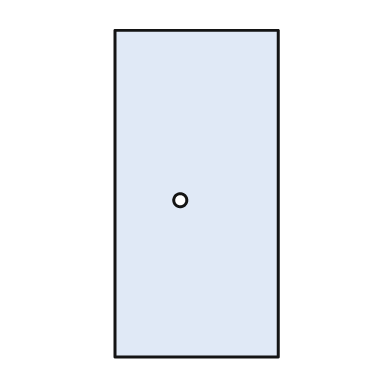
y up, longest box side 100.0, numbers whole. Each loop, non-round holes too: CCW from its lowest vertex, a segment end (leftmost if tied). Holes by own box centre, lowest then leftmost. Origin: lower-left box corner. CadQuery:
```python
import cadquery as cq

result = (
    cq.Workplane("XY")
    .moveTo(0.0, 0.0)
    .lineTo(50.0, 0.0)
    .lineTo(50.0, 100.0)
    .lineTo(0.0, 100.0)
    .close()
    .moveTo(20.0, 48.0)
    .circle(2.0)
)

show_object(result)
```